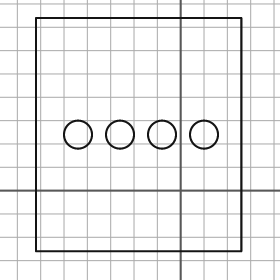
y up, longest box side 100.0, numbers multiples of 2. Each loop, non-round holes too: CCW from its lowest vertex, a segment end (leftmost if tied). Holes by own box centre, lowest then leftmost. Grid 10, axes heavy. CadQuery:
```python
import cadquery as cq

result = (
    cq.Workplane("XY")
    .moveTo(-62.0, -26.0)
    .lineTo(26.0, -26.0)
    .lineTo(26.0, 74.0)
    .lineTo(-62.0, 74.0)
    .close()
    .moveTo(-44.0, 24.0)
    .circle(6.0)
    .moveTo(-26.0, 24.0)
    .circle(6.0)
    .moveTo(-8.0, 24.0)
    .circle(6.0)
    .moveTo(10.0, 24.0)
    .circle(6.0)
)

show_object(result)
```